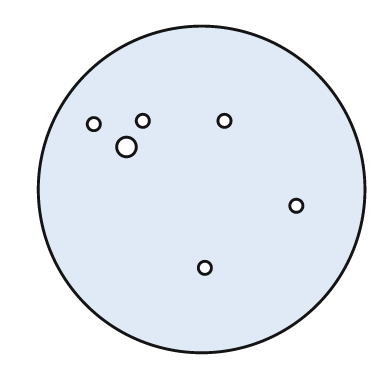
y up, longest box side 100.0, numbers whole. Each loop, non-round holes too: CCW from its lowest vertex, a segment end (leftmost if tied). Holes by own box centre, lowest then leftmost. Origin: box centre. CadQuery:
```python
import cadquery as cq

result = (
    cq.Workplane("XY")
    .moveTo(0.0, 0.0)
    .circle(50.0)
    .moveTo(1.0, -24.0)
    .circle(2.0)
    .moveTo(29.0, -5.0)
    .circle(2.0)
    .moveTo(-23.0, 13.0)
    .circle(3.0)
    .moveTo(-33.0, 20.0)
    .circle(2.0)
    .moveTo(-18.0, 21.0)
    .circle(2.0)
    .moveTo(7.0, 21.0)
    .circle(2.0)
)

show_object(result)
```